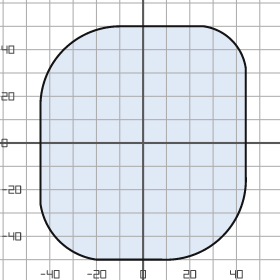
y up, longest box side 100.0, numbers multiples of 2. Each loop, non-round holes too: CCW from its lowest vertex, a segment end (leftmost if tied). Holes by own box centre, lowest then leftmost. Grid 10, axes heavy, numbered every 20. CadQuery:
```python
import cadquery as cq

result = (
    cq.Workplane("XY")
    .moveTo(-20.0, -50.0)
    .lineTo(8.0, -50.0)
    .threePointArc((34.0, -40.0), (44.0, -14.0))
    .lineTo(44.0, 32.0)
    .threePointArc((38.0, 44.0), (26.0, 50.0))
    .lineTo(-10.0, 50.0)
    .threePointArc((-34.0, 40.0), (-44.0, 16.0))
    .lineTo(-44.0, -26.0)
    .threePointArc((-36.0, -42.0), (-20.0, -50.0))
    .close()
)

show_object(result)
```